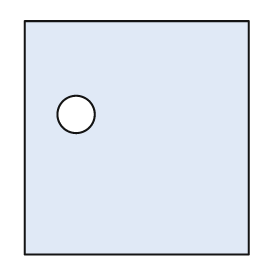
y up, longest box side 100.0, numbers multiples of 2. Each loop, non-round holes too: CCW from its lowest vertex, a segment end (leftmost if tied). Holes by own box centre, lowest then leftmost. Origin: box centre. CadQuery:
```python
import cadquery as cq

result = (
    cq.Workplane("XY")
    .moveTo(-48.0, -50.0)
    .lineTo(48.0, -50.0)
    .lineTo(48.0, 50.0)
    .lineTo(-48.0, 50.0)
    .close()
    .moveTo(-26.0, 10.0)
    .circle(8.0)
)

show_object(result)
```